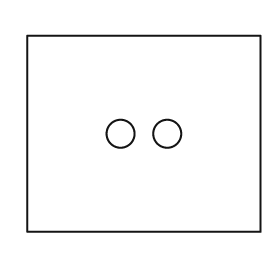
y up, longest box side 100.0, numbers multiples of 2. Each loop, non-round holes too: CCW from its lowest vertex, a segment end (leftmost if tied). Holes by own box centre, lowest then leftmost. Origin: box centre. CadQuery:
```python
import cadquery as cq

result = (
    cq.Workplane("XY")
    .moveTo(-50.0, -42.0)
    .lineTo(50.0, -42.0)
    .lineTo(50.0, 42.0)
    .lineTo(-50.0, 42.0)
    .close()
    .moveTo(-10.0, 0.0)
    .circle(6.0)
    .moveTo(10.0, 0.0)
    .circle(6.0)
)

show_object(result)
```